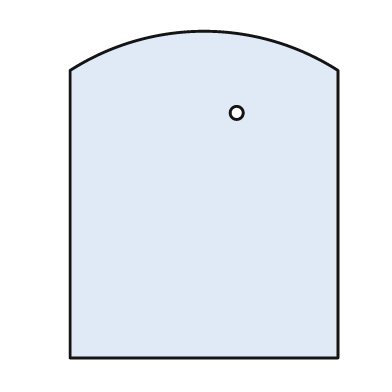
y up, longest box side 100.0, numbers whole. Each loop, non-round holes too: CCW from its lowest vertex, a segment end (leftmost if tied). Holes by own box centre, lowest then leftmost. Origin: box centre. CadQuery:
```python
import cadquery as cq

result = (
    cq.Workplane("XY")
    .moveTo(-41.0, -50.0)
    .lineTo(41.0, -50.0)
    .lineTo(41.0, 38.0)
    .threePointArc((0.0, 50.0), (-41.0, 38.0))
    .close()
    .moveTo(10.0, 25.0)
    .circle(2.0)
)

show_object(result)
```